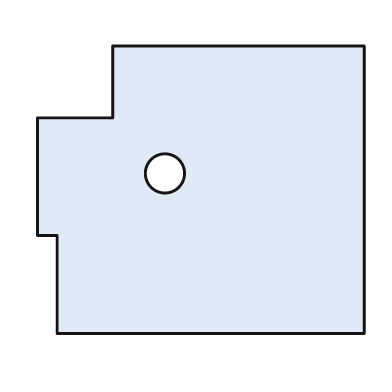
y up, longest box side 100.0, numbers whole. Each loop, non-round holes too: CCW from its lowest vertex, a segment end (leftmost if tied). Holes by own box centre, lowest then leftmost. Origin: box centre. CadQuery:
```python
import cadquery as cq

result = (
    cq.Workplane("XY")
    .moveTo(-44.0, -44.0)
    .lineTo(50.0, -44.0)
    .lineTo(50.0, 44.0)
    .lineTo(-27.0, 44.0)
    .lineTo(-27.0, 22.0)
    .lineTo(-50.0, 22.0)
    .lineTo(-50.0, -14.0)
    .lineTo(-44.0, -14.0)
    .close()
    .moveTo(-11.0, 5.0)
    .circle(6.0)
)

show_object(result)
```